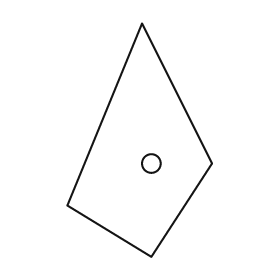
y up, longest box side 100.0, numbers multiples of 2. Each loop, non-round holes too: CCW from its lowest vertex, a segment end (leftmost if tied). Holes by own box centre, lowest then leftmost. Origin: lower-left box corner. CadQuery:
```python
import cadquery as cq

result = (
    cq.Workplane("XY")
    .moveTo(36.0, 0.0)
    .lineTo(62.0, 40.0)
    .lineTo(32.0, 100.0)
    .lineTo(0.0, 22.0)
    .close()
    .moveTo(36.0, 40.0)
    .circle(4.0)
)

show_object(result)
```